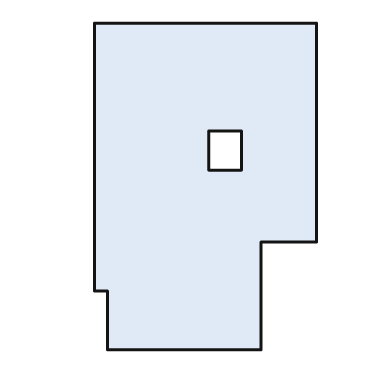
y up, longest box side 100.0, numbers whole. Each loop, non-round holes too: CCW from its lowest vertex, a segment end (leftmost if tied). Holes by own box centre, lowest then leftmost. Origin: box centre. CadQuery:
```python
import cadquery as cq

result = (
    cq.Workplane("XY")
    .moveTo(-30.0, -50.0)
    .lineTo(17.0, -50.0)
    .lineTo(17.0, -17.0)
    .lineTo(34.0, -17.0)
    .lineTo(34.0, 50.0)
    .lineTo(-34.0, 50.0)
    .lineTo(-34.0, -32.0)
    .lineTo(-30.0, -32.0)
    .close()
    .moveTo(1.0, 5.0)
    .lineTo(11.0, 5.0)
    .lineTo(11.0, 17.0)
    .lineTo(1.0, 17.0)
    .close()
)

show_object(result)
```